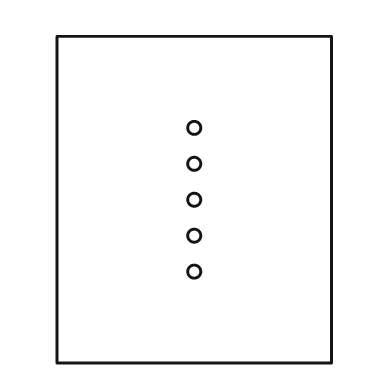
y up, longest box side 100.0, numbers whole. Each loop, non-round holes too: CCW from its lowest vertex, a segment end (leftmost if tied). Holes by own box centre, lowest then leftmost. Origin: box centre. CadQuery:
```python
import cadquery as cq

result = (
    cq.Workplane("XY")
    .moveTo(-42.0, -50.0)
    .lineTo(42.0, -50.0)
    .lineTo(42.0, 50.0)
    .lineTo(-42.0, 50.0)
    .close()
    .moveTo(0.0, -22.0)
    .circle(2.0)
    .moveTo(0.0, -11.0)
    .circle(2.0)
    .moveTo(0.0, 0.0)
    .circle(2.0)
    .moveTo(0.0, 11.0)
    .circle(2.0)
    .moveTo(0.0, 22.0)
    .circle(2.0)
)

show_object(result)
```